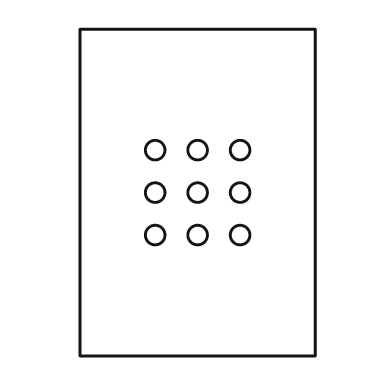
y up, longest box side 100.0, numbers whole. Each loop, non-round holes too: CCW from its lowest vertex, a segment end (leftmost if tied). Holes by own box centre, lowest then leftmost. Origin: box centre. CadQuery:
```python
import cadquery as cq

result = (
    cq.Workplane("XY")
    .moveTo(-36.0, -50.0)
    .lineTo(36.0, -50.0)
    .lineTo(36.0, 50.0)
    .lineTo(-36.0, 50.0)
    .close()
    .moveTo(-13.0, -13.0)
    .circle(3.0)
    .moveTo(0.0, -13.0)
    .circle(3.0)
    .moveTo(13.0, -13.0)
    .circle(3.0)
    .moveTo(-13.0, 0.0)
    .circle(3.0)
    .moveTo(0.0, 0.0)
    .circle(3.0)
    .moveTo(13.0, 0.0)
    .circle(3.0)
    .moveTo(-13.0, 13.0)
    .circle(3.0)
    .moveTo(0.0, 13.0)
    .circle(3.0)
    .moveTo(13.0, 13.0)
    .circle(3.0)
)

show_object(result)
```